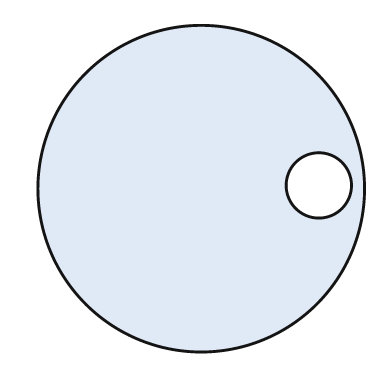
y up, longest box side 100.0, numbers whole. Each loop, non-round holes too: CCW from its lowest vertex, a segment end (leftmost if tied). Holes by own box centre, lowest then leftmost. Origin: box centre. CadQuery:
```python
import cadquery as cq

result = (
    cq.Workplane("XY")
    .moveTo(0.0, 0.0)
    .circle(50.0)
    .moveTo(36.0, 1.0)
    .circle(10.0)
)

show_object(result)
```